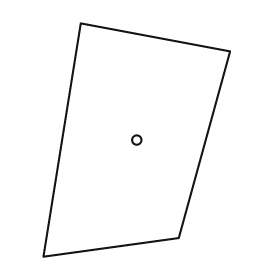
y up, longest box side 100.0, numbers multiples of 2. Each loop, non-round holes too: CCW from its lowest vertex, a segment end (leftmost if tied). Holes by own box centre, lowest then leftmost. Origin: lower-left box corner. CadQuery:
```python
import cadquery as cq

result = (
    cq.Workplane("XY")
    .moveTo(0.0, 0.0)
    .lineTo(58.0, 8.0)
    .lineTo(80.0, 88.0)
    .lineTo(16.0, 100.0)
    .close()
    .moveTo(40.0, 50.0)
    .circle(2.0)
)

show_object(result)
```